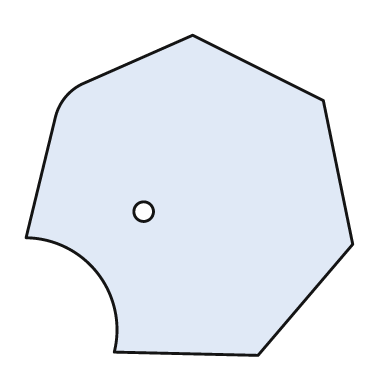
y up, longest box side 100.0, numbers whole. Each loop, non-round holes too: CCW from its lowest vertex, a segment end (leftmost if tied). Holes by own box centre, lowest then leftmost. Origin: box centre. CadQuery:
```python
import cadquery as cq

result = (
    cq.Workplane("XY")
    .moveTo(21.0, -49.0)
    .lineTo(50.0, -15.0)
    .lineTo(41.0, 29.0)
    .lineTo(1.0, 49.0)
    .lineTo(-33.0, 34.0)
    .threePointArc((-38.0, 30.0), (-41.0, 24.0))
    .lineTo(-50.0, -13.0)
    .threePointArc((-28.0, -24.0), (-23.0, -48.0))
    .close()
    .moveTo(-14.0, -5.0)
    .circle(3.0)
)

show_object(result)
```